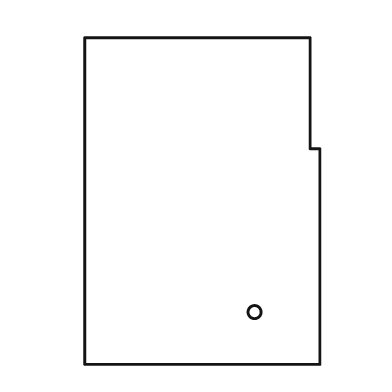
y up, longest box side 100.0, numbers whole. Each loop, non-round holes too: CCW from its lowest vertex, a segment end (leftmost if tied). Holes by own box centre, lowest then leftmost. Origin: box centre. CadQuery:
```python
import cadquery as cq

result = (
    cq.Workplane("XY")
    .moveTo(-36.0, -50.0)
    .lineTo(36.0, -50.0)
    .lineTo(36.0, 16.0)
    .lineTo(33.0, 16.0)
    .lineTo(33.0, 50.0)
    .lineTo(-36.0, 50.0)
    .close()
    .moveTo(16.0, -34.0)
    .circle(2.0)
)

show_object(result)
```